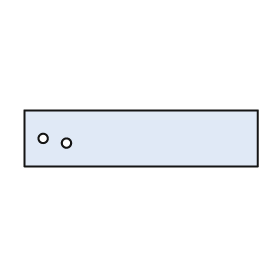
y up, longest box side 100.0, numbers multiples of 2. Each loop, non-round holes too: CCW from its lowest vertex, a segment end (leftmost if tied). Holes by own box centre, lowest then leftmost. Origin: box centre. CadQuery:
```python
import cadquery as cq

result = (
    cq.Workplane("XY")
    .moveTo(-50.0, -12.0)
    .lineTo(50.0, -12.0)
    .lineTo(50.0, 12.0)
    .lineTo(-50.0, 12.0)
    .close()
    .moveTo(-32.0, -2.0)
    .circle(2.0)
    .moveTo(-42.0, 0.0)
    .circle(2.0)
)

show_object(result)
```